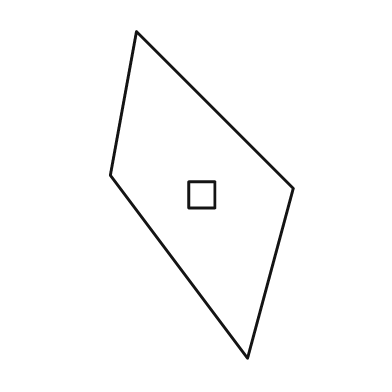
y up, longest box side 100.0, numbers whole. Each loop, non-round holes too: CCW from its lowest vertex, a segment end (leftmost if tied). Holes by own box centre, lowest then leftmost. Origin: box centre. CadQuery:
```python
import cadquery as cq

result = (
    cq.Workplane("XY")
    .moveTo(14.0, -50.0)
    .lineTo(28.0, 2.0)
    .lineTo(-20.0, 50.0)
    .lineTo(-28.0, 6.0)
    .close()
    .moveTo(-4.0, -4.0)
    .lineTo(4.0, -4.0)
    .lineTo(4.0, 4.0)
    .lineTo(-4.0, 4.0)
    .close()
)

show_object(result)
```